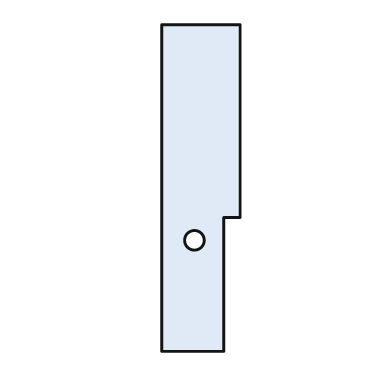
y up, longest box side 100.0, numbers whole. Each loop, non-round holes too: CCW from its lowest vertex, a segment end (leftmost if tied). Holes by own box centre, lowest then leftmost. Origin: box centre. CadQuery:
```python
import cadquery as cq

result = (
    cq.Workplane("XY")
    .moveTo(-12.0, -50.0)
    .lineTo(7.0, -50.0)
    .lineTo(7.0, -9.0)
    .lineTo(12.0, -9.0)
    .lineTo(12.0, 50.0)
    .lineTo(-12.0, 50.0)
    .close()
    .moveTo(-2.0, -16.0)
    .circle(3.0)
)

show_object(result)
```